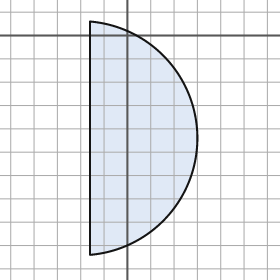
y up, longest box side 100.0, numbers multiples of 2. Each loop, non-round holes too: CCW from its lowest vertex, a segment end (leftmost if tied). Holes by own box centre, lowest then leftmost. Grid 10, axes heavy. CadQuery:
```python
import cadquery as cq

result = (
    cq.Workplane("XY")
    .moveTo(-16.0, -94.0)
    .threePointArc((30.0, -44.0), (-16.0, 6.0))
    .close()
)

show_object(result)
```